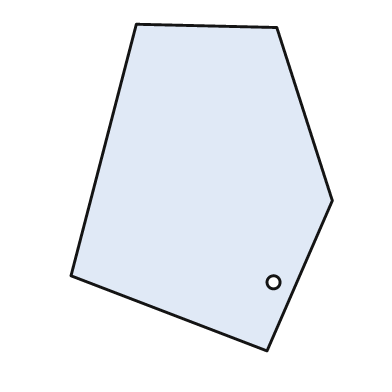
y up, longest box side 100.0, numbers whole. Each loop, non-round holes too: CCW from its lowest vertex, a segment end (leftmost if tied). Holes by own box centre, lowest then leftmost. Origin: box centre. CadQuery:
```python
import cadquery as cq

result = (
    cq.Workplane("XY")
    .moveTo(20.0, -50.0)
    .lineTo(40.0, -4.0)
    .lineTo(23.0, 49.0)
    .lineTo(-20.0, 50.0)
    .lineTo(-40.0, -27.0)
    .close()
    .moveTo(22.0, -29.0)
    .circle(2.0)
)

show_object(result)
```